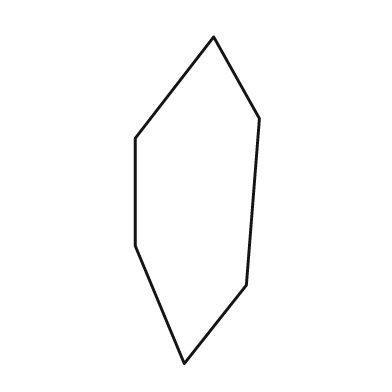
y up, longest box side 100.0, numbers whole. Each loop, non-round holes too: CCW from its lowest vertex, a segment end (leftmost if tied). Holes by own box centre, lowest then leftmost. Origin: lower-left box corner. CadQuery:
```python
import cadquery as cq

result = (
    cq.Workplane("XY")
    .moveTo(15.0, 0.0)
    .lineTo(34.0, 24.0)
    .lineTo(38.0, 75.0)
    .lineTo(24.0, 100.0)
    .lineTo(0.0, 69.0)
    .lineTo(0.0, 36.0)
    .close()
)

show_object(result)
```